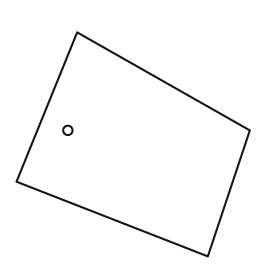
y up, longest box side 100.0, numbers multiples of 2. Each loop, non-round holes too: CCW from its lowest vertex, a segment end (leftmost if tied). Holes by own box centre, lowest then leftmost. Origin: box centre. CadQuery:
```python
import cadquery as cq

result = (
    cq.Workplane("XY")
    .moveTo(32.0, -48.0)
    .lineTo(50.0, 6.0)
    .lineTo(-24.0, 48.0)
    .lineTo(-50.0, -16.0)
    .close()
    .moveTo(-28.0, 6.0)
    .circle(2.0)
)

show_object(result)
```